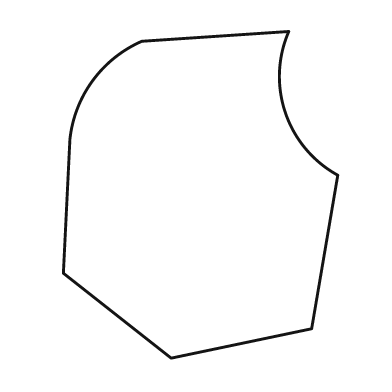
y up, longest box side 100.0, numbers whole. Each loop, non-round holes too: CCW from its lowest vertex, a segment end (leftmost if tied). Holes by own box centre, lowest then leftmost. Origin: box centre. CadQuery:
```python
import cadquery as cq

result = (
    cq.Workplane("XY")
    .moveTo(-9.0, -50.0)
    .lineTo(34.0, -41.0)
    .lineTo(42.0, 6.0)
    .threePointArc((26.0, 25.0), (27.0, 50.0))
    .lineTo(-18.0, 47.0)
    .threePointArc((-33.0, 35.0), (-40.0, 17.0))
    .lineTo(-42.0, -24.0)
    .close()
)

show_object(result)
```